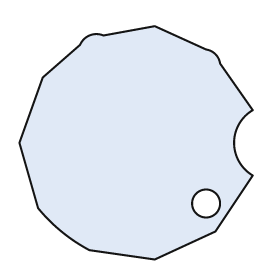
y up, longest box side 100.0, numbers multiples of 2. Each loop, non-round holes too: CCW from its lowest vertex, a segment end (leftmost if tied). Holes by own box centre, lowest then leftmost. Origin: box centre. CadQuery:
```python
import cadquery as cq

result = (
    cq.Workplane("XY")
    .moveTo(8.0, -50.0)
    .lineTo(34.0, -38.0)
    .lineTo(50.0, -14.0)
    .threePointArc((42.0, 0.0), (50.0, 14.0))
    .lineTo(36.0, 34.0)
    .threePointArc((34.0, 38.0), (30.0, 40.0))
    .lineTo(8.0, 50.0)
    .lineTo(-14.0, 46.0)
    .threePointArc((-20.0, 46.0), (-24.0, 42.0))
    .lineTo(-40.0, 28.0)
    .lineTo(-50.0, 0.0)
    .lineTo(-42.0, -28.0)
    .threePointArc((-32.0, -38.0), (-20.0, -46.0))
    .close()
    .moveTo(30.0, -26.0)
    .circle(6.0)
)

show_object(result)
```